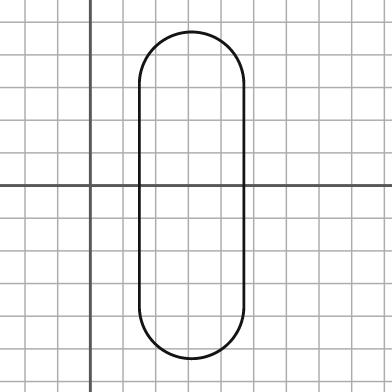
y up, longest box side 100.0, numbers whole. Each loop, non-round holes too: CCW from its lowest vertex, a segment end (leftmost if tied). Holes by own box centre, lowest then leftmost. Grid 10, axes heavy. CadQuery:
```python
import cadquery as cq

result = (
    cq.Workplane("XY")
    .moveTo(15.0, -37.0)
    .threePointArc((31.0, -53.0), (47.0, -37.0))
    .lineTo(47.0, 31.0)
    .threePointArc((31.0, 47.0), (15.0, 31.0))
    .close()
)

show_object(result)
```